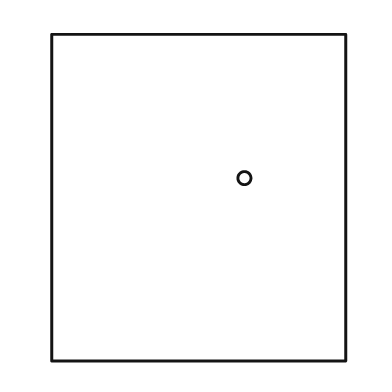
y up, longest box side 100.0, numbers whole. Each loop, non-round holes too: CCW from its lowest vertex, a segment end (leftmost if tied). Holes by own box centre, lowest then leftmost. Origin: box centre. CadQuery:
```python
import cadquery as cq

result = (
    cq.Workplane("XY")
    .moveTo(-45.0, -50.0)
    .lineTo(45.0, -50.0)
    .lineTo(45.0, 50.0)
    .lineTo(-45.0, 50.0)
    .close()
    .moveTo(14.0, 6.0)
    .circle(2.0)
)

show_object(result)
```